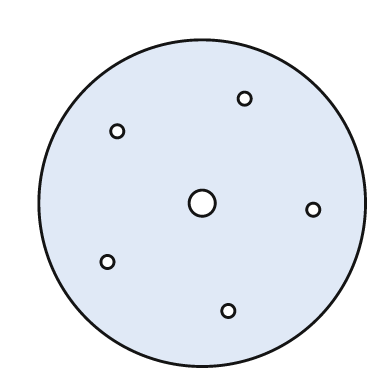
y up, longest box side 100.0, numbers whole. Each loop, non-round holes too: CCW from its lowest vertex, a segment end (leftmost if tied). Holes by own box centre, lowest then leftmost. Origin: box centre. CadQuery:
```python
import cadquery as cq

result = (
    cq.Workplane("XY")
    .moveTo(0.0, 0.0)
    .circle(50.0)
    .moveTo(8.0, -33.0)
    .circle(2.0)
    .moveTo(-29.0, -18.0)
    .circle(2.0)
    .moveTo(34.0, -2.0)
    .circle(2.0)
    .moveTo(0.0, 0.0)
    .circle(4.0)
    .moveTo(-26.0, 22.0)
    .circle(2.0)
    .moveTo(13.0, 32.0)
    .circle(2.0)
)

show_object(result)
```